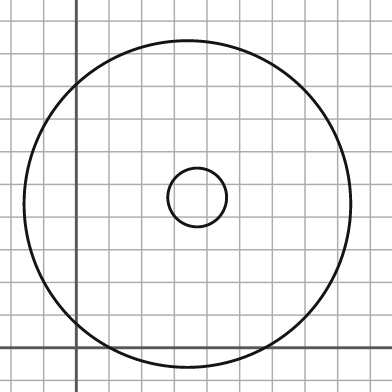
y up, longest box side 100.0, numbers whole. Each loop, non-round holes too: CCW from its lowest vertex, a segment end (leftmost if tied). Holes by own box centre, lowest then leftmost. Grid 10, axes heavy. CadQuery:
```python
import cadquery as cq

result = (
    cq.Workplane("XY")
    .moveTo(34.0, 44.0)
    .circle(50.0)
    .moveTo(37.0, 46.0)
    .circle(9.0)
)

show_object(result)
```